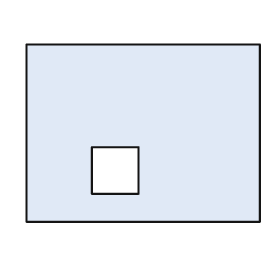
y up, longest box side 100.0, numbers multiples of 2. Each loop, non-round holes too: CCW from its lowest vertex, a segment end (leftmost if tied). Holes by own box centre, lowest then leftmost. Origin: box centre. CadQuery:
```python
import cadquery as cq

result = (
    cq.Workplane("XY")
    .moveTo(-50.0, -38.0)
    .lineTo(50.0, -38.0)
    .lineTo(50.0, 38.0)
    .lineTo(-50.0, 38.0)
    .close()
    .moveTo(-22.0, -26.0)
    .lineTo(-2.0, -26.0)
    .lineTo(-2.0, -6.0)
    .lineTo(-22.0, -6.0)
    .close()
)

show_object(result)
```